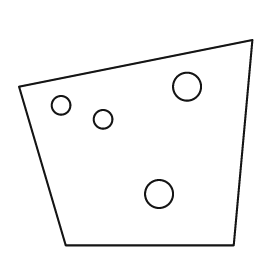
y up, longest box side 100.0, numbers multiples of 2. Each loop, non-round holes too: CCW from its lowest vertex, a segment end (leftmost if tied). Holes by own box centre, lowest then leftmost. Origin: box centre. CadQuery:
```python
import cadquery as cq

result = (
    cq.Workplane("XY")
    .moveTo(-30.0, -44.0)
    .lineTo(42.0, -44.0)
    .lineTo(50.0, 44.0)
    .lineTo(-50.0, 24.0)
    .close()
    .moveTo(10.0, -22.0)
    .circle(6.0)
    .moveTo(-14.0, 10.0)
    .circle(4.0)
    .moveTo(-32.0, 16.0)
    .circle(4.0)
    .moveTo(22.0, 24.0)
    .circle(6.0)
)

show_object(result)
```